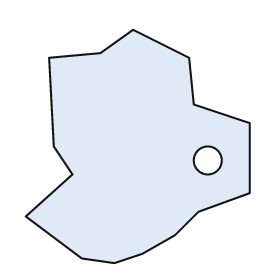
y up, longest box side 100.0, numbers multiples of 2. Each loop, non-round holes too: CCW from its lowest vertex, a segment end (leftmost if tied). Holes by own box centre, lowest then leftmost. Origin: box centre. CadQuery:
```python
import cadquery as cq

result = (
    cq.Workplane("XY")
    .moveTo(-10.0, -50.0)
    .lineTo(2.0, -46.0)
    .lineTo(16.0, -38.0)
    .lineTo(26.0, -28.0)
    .lineTo(48.0, -20.0)
    .lineTo(48.0, 10.0)
    .lineTo(24.0, 18.0)
    .lineTo(22.0, 38.0)
    .lineTo(-2.0, 50.0)
    .lineTo(-16.0, 40.0)
    .lineTo(-38.0, 38.0)
    .lineTo(-36.0, 0.0)
    .lineTo(-28.0, -12.0)
    .lineTo(-48.0, -30.0)
    .lineTo(-24.0, -48.0)
    .close()
    .moveTo(30.0, -6.0)
    .circle(6.0)
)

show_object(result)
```